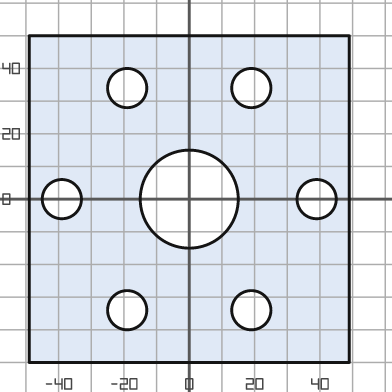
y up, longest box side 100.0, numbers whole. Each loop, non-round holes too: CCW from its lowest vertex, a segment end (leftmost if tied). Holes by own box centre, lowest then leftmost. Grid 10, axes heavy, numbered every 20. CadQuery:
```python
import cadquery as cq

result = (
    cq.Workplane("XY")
    .moveTo(-49.0, -50.0)
    .lineTo(49.0, -50.0)
    .lineTo(49.0, 50.0)
    .lineTo(-49.0, 50.0)
    .close()
    .moveTo(-19.0, -34.0)
    .circle(6.0)
    .moveTo(19.0, -34.0)
    .circle(6.0)
    .moveTo(-39.0, 0.0)
    .circle(6.0)
    .moveTo(0.0, 0.0)
    .circle(15.0)
    .moveTo(39.0, 0.0)
    .circle(6.0)
    .moveTo(-19.0, 34.0)
    .circle(6.0)
    .moveTo(19.0, 34.0)
    .circle(6.0)
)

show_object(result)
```